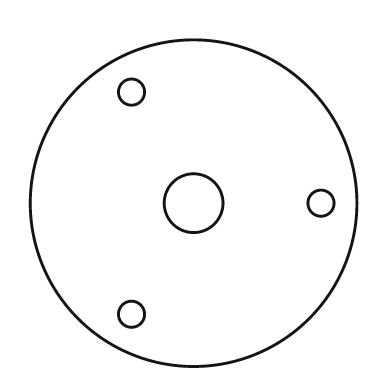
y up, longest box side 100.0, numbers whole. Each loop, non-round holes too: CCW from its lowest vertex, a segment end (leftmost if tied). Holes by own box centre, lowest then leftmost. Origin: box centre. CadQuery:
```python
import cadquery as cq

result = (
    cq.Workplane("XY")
    .moveTo(0.0, 0.0)
    .circle(50.0)
    .moveTo(-19.0, -34.0)
    .circle(4.0)
    .moveTo(0.0, 0.0)
    .circle(9.0)
    .moveTo(39.0, 0.0)
    .circle(4.0)
    .moveTo(-19.0, 34.0)
    .circle(4.0)
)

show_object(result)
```